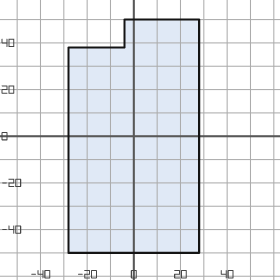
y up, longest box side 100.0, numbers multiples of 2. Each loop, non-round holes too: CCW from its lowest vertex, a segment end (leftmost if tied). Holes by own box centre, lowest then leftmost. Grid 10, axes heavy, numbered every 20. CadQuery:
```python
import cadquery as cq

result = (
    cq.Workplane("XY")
    .moveTo(-28.0, -50.0)
    .lineTo(28.0, -50.0)
    .lineTo(28.0, 50.0)
    .lineTo(-4.0, 50.0)
    .lineTo(-4.0, 38.0)
    .lineTo(-28.0, 38.0)
    .close()
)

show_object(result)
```